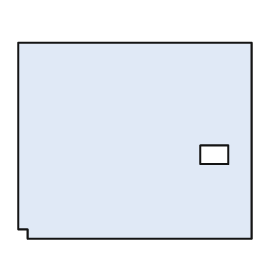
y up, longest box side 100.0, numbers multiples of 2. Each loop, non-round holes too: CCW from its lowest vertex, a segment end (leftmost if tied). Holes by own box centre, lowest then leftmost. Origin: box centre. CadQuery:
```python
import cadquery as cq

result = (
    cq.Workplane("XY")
    .moveTo(-46.0, -42.0)
    .lineTo(50.0, -42.0)
    .lineTo(50.0, 42.0)
    .lineTo(-50.0, 42.0)
    .lineTo(-50.0, -38.0)
    .lineTo(-46.0, -38.0)
    .close()
    .moveTo(28.0, -10.0)
    .lineTo(40.0, -10.0)
    .lineTo(40.0, -2.0)
    .lineTo(28.0, -2.0)
    .close()
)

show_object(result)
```